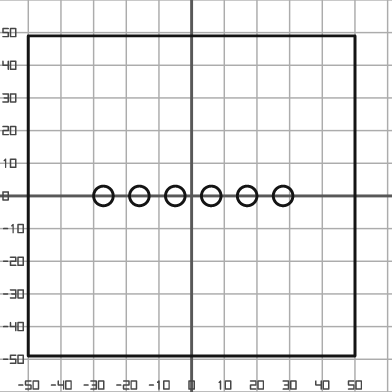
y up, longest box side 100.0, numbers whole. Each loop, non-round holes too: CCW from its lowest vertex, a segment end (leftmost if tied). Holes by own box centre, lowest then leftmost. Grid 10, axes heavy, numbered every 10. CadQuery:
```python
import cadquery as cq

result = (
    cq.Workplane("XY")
    .moveTo(-50.0, -49.0)
    .lineTo(50.0, -49.0)
    .lineTo(50.0, 49.0)
    .lineTo(-50.0, 49.0)
    .close()
    .moveTo(-27.0, 0.0)
    .circle(3.0)
    .moveTo(-16.0, 0.0)
    .circle(3.0)
    .moveTo(-5.0, 0.0)
    .circle(3.0)
    .moveTo(6.0, 0.0)
    .circle(3.0)
    .moveTo(17.0, 0.0)
    .circle(3.0)
    .moveTo(28.0, 0.0)
    .circle(3.0)
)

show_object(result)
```